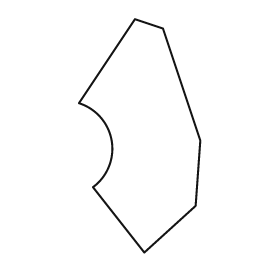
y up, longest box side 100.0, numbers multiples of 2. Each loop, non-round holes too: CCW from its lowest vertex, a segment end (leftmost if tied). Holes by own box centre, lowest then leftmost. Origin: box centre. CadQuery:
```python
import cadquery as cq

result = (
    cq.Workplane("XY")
    .moveTo(2.0, -50.0)
    .lineTo(24.0, -30.0)
    .lineTo(26.0, -2.0)
    .lineTo(10.0, 46.0)
    .lineTo(-2.0, 50.0)
    .lineTo(-26.0, 14.0)
    .threePointArc((-12.0, -2.0), (-20.0, -22.0))
    .close()
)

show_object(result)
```